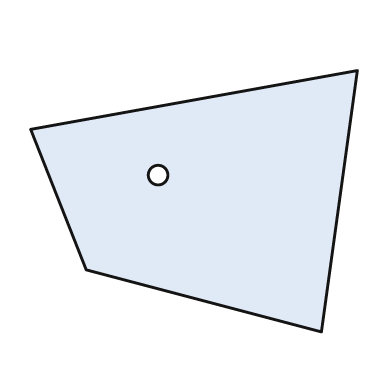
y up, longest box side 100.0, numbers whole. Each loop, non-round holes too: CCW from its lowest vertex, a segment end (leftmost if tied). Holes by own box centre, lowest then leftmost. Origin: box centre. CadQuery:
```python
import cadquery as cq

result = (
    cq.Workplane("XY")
    .moveTo(39.0, -40.0)
    .lineTo(50.0, 40.0)
    .lineTo(-50.0, 22.0)
    .lineTo(-33.0, -21.0)
    .close()
    .moveTo(-11.0, 8.0)
    .circle(3.0)
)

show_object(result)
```